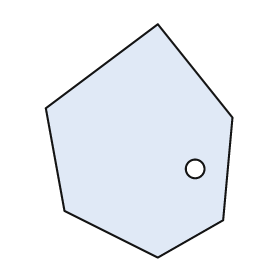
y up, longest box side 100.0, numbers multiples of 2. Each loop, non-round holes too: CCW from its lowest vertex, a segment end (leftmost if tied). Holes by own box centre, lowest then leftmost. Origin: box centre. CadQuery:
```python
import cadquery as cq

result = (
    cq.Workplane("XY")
    .moveTo(8.0, -50.0)
    .lineTo(36.0, -34.0)
    .lineTo(40.0, 10.0)
    .lineTo(8.0, 50.0)
    .lineTo(-40.0, 14.0)
    .lineTo(-32.0, -30.0)
    .close()
    .moveTo(24.0, -12.0)
    .circle(4.0)
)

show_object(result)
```